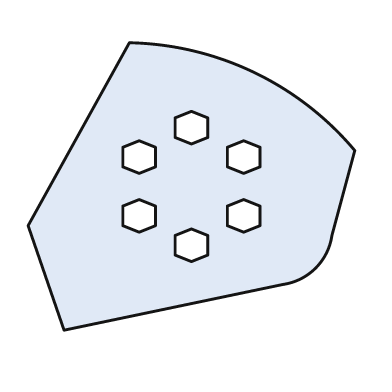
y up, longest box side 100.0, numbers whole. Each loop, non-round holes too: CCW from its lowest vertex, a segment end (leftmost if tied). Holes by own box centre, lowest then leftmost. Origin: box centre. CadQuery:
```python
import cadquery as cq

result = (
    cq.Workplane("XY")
    .moveTo(-39.0, -44.0)
    .lineTo(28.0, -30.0)
    .threePointArc((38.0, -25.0), (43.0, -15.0))
    .lineTo(50.0, 11.0)
    .threePointArc((19.0, 35.0), (-19.0, 44.0))
    .lineTo(-50.0, -12.0)
    .close()
    .moveTo(0.0, -23.0)
    .lineTo(5.0, -21.0)
    .lineTo(5.0, -15.0)
    .lineTo(0.0, -13.0)
    .lineTo(-5.0, -15.0)
    .lineTo(-5.0, -21.0)
    .close()
    .moveTo(-16.0, -14.0)
    .lineTo(-11.0, -12.0)
    .lineTo(-11.0, -6.0)
    .lineTo(-16.0, -4.0)
    .lineTo(-21.0, -6.0)
    .lineTo(-21.0, -12.0)
    .close()
    .moveTo(16.0, -14.0)
    .lineTo(21.0, -12.0)
    .lineTo(21.0, -6.0)
    .lineTo(16.0, -4.0)
    .lineTo(11.0, -6.0)
    .lineTo(11.0, -12.0)
    .close()
    .moveTo(-16.0, 4.0)
    .lineTo(-11.0, 6.0)
    .lineTo(-11.0, 12.0)
    .lineTo(-16.0, 14.0)
    .lineTo(-21.0, 12.0)
    .lineTo(-21.0, 6.0)
    .close()
    .moveTo(16.0, 4.0)
    .lineTo(21.0, 6.0)
    .lineTo(21.0, 12.0)
    .lineTo(16.0, 14.0)
    .lineTo(11.0, 12.0)
    .lineTo(11.0, 6.0)
    .close()
    .moveTo(0.0, 13.0)
    .lineTo(5.0, 15.0)
    .lineTo(5.0, 21.0)
    .lineTo(0.0, 23.0)
    .lineTo(-5.0, 21.0)
    .lineTo(-5.0, 15.0)
    .close()
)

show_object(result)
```